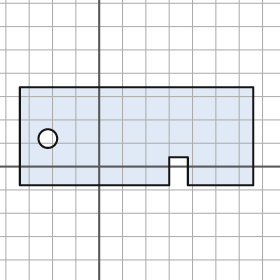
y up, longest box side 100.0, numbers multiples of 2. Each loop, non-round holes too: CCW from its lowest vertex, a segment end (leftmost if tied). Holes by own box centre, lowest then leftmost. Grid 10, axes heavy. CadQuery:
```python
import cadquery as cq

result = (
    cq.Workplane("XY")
    .moveTo(-34.0, -8.0)
    .lineTo(30.0, -8.0)
    .lineTo(30.0, 4.0)
    .lineTo(38.0, 4.0)
    .lineTo(38.0, -8.0)
    .lineTo(66.0, -8.0)
    .lineTo(66.0, 34.0)
    .lineTo(-34.0, 34.0)
    .close()
    .moveTo(-22.0, 12.0)
    .circle(4.0)
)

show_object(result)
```